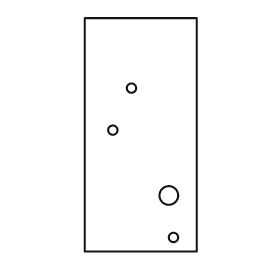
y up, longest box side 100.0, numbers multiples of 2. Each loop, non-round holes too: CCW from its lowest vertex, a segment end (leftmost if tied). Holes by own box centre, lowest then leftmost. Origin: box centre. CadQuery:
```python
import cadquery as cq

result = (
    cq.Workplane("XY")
    .moveTo(-24.0, -50.0)
    .lineTo(24.0, -50.0)
    .lineTo(24.0, 50.0)
    .lineTo(-24.0, 50.0)
    .close()
    .moveTo(14.0, -44.0)
    .circle(2.0)
    .moveTo(12.0, -26.0)
    .circle(4.0)
    .moveTo(-12.0, 2.0)
    .circle(2.0)
    .moveTo(-4.0, 20.0)
    .circle(2.0)
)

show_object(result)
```